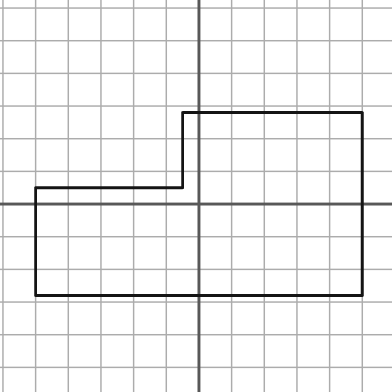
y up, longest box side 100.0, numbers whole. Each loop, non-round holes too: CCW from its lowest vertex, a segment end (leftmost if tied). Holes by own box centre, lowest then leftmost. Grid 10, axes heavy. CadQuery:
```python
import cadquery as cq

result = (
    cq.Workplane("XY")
    .moveTo(-50.0, -28.0)
    .lineTo(50.0, -28.0)
    .lineTo(50.0, 28.0)
    .lineTo(-5.0, 28.0)
    .lineTo(-5.0, 5.0)
    .lineTo(-50.0, 5.0)
    .close()
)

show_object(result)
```